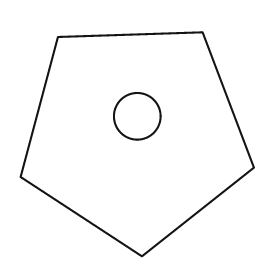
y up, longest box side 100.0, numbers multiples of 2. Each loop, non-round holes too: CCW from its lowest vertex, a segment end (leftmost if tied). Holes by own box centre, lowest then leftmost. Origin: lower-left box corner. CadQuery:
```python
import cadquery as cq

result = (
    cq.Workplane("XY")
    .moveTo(52.0, 0.0)
    .lineTo(100.0, 38.0)
    .lineTo(78.0, 96.0)
    .lineTo(16.0, 94.0)
    .lineTo(0.0, 34.0)
    .close()
    .moveTo(50.0, 60.0)
    .circle(10.0)
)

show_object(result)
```